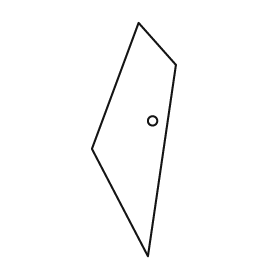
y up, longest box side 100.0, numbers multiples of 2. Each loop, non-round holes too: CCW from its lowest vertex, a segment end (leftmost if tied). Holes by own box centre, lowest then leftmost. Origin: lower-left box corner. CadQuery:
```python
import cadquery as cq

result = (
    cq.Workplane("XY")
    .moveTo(24.0, 0.0)
    .lineTo(36.0, 82.0)
    .lineTo(20.0, 100.0)
    .lineTo(0.0, 46.0)
    .close()
    .moveTo(26.0, 58.0)
    .circle(2.0)
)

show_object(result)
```